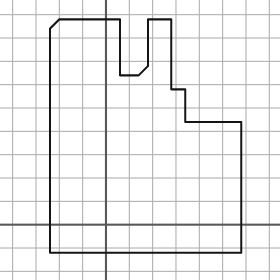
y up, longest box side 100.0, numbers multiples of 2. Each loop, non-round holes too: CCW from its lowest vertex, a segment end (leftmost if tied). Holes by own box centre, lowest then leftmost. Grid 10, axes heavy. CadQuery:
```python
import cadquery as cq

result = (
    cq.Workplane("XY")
    .moveTo(-24.0, -12.0)
    .lineTo(58.0, -12.0)
    .lineTo(58.0, 44.0)
    .lineTo(34.0, 44.0)
    .lineTo(34.0, 58.0)
    .lineTo(28.0, 58.0)
    .lineTo(28.0, 88.0)
    .lineTo(18.0, 88.0)
    .lineTo(18.0, 68.0)
    .lineTo(14.0, 64.0)
    .lineTo(6.0, 64.0)
    .lineTo(6.0, 88.0)
    .lineTo(-20.0, 88.0)
    .lineTo(-24.0, 84.0)
    .close()
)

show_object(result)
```